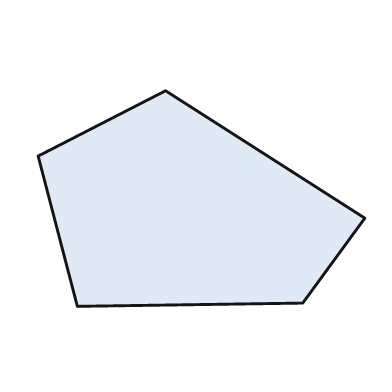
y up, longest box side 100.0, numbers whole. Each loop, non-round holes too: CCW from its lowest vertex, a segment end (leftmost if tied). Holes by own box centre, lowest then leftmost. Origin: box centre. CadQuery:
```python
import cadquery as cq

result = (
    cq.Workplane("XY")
    .moveTo(-38.0, -33.0)
    .lineTo(31.0, -32.0)
    .lineTo(50.0, -6.0)
    .lineTo(-11.0, 33.0)
    .lineTo(-50.0, 13.0)
    .close()
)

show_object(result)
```